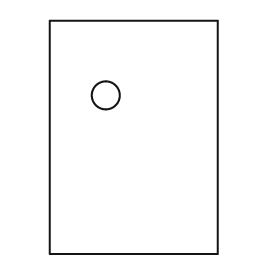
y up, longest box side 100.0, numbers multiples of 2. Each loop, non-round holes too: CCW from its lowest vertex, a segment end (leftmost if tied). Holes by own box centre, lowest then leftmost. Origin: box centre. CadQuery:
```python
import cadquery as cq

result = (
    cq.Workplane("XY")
    .moveTo(-36.0, -50.0)
    .lineTo(36.0, -50.0)
    .lineTo(36.0, 50.0)
    .lineTo(-36.0, 50.0)
    .close()
    .moveTo(-12.0, 18.0)
    .circle(6.0)
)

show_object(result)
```